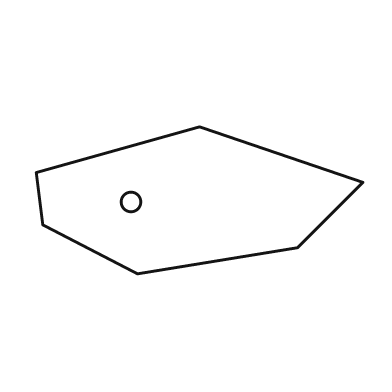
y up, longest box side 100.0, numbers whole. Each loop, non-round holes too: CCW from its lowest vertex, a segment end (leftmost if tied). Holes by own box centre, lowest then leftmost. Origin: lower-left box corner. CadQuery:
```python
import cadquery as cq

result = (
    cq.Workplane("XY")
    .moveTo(31.0, 0.0)
    .lineTo(80.0, 8.0)
    .lineTo(100.0, 28.0)
    .lineTo(50.0, 45.0)
    .lineTo(0.0, 31.0)
    .lineTo(2.0, 15.0)
    .close()
    .moveTo(29.0, 22.0)
    .circle(3.0)
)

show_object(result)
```